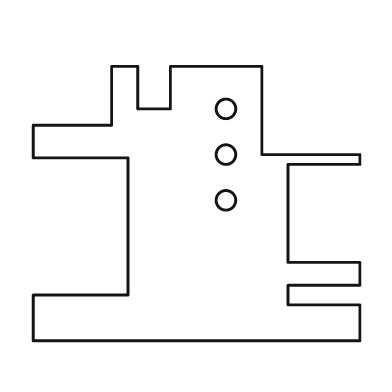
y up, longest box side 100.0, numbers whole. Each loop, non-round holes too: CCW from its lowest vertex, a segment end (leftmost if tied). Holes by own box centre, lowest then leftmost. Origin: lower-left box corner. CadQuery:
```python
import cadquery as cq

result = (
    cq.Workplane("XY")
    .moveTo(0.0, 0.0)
    .lineTo(100.0, 0.0)
    .lineTo(100.0, 11.0)
    .lineTo(78.0, 11.0)
    .lineTo(78.0, 17.0)
    .lineTo(100.0, 17.0)
    .lineTo(100.0, 24.0)
    .lineTo(78.0, 24.0)
    .lineTo(78.0, 54.0)
    .lineTo(100.0, 54.0)
    .lineTo(100.0, 57.0)
    .lineTo(70.0, 57.0)
    .lineTo(70.0, 84.0)
    .lineTo(42.0, 84.0)
    .lineTo(42.0, 71.0)
    .lineTo(32.0, 71.0)
    .lineTo(32.0, 84.0)
    .lineTo(24.0, 84.0)
    .lineTo(24.0, 66.0)
    .lineTo(0.0, 66.0)
    .lineTo(0.0, 56.0)
    .lineTo(29.0, 56.0)
    .lineTo(29.0, 14.0)
    .lineTo(0.0, 14.0)
    .close()
    .moveTo(59.0, 43.0)
    .circle(3.0)
    .moveTo(59.0, 57.0)
    .circle(3.0)
    .moveTo(59.0, 71.0)
    .circle(3.0)
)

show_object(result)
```